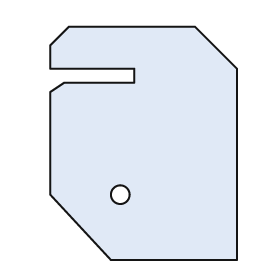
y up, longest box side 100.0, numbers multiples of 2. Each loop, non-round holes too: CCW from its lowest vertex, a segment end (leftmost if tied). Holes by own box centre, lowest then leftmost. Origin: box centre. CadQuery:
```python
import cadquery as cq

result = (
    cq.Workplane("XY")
    .moveTo(-14.0, -50.0)
    .lineTo(40.0, -50.0)
    .lineTo(40.0, 32.0)
    .lineTo(22.0, 50.0)
    .lineTo(-32.0, 50.0)
    .lineTo(-40.0, 42.0)
    .lineTo(-40.0, 32.0)
    .lineTo(-4.0, 32.0)
    .lineTo(-4.0, 26.0)
    .lineTo(-34.0, 26.0)
    .lineTo(-40.0, 22.0)
    .lineTo(-40.0, -22.0)
    .close()
    .moveTo(-10.0, -22.0)
    .circle(4.0)
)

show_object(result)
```